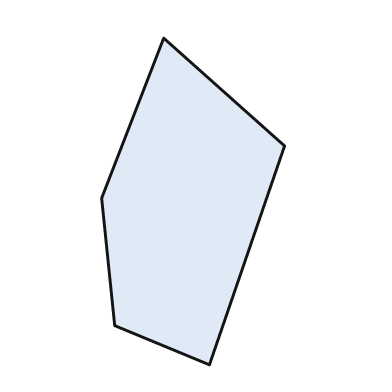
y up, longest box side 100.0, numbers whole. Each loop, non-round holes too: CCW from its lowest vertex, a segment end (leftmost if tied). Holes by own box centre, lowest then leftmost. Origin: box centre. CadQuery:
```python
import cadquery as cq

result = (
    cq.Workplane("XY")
    .moveTo(5.0, -50.0)
    .lineTo(28.0, 17.0)
    .lineTo(-9.0, 50.0)
    .lineTo(-28.0, 1.0)
    .lineTo(-24.0, -38.0)
    .close()
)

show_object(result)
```